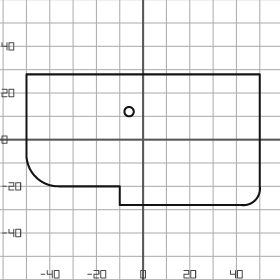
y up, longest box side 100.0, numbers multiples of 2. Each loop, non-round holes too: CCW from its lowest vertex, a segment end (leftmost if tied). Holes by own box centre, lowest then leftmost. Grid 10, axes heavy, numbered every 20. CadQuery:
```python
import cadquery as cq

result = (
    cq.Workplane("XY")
    .moveTo(-10.0, -28.0)
    .lineTo(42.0, -28.0)
    .threePointArc((48.0, -26.0), (50.0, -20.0))
    .lineTo(50.0, 28.0)
    .lineTo(-50.0, 28.0)
    .lineTo(-50.0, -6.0)
    .threePointArc((-46.0, -16.0), (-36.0, -20.0))
    .lineTo(-10.0, -20.0)
    .close()
    .moveTo(-6.0, 12.0)
    .circle(2.0)
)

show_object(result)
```